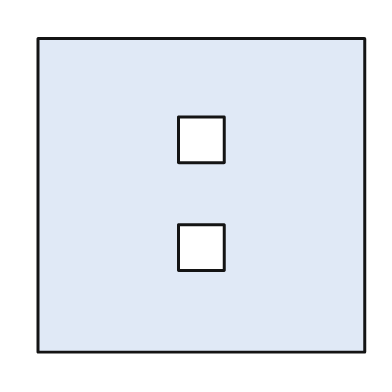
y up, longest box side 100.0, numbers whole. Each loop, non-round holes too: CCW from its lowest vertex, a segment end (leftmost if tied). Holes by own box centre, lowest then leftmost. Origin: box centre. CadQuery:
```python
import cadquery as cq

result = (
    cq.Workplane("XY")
    .moveTo(-50.0, -48.0)
    .lineTo(50.0, -48.0)
    .lineTo(50.0, 48.0)
    .lineTo(-50.0, 48.0)
    .close()
    .moveTo(-7.0, -23.0)
    .lineTo(7.0, -23.0)
    .lineTo(7.0, -9.0)
    .lineTo(-7.0, -9.0)
    .close()
    .moveTo(-7.0, 10.0)
    .lineTo(7.0, 10.0)
    .lineTo(7.0, 24.0)
    .lineTo(-7.0, 24.0)
    .close()
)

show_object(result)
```